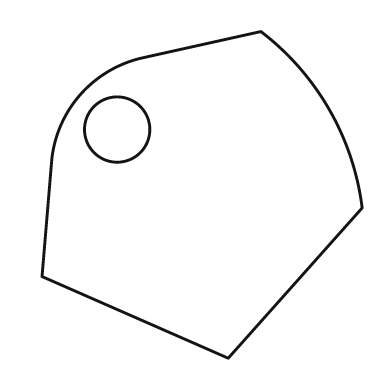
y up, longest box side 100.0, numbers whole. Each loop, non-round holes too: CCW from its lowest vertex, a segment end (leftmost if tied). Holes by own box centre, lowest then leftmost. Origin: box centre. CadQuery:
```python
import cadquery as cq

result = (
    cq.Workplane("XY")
    .moveTo(8.0, -50.0)
    .lineTo(49.0, -4.0)
    .threePointArc((39.0, 26.0), (18.0, 50.0))
    .lineTo(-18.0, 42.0)
    .threePointArc((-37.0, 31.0), (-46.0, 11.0))
    .lineTo(-49.0, -25.0)
    .close()
    .moveTo(-26.0, 20.0)
    .circle(10.0)
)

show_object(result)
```